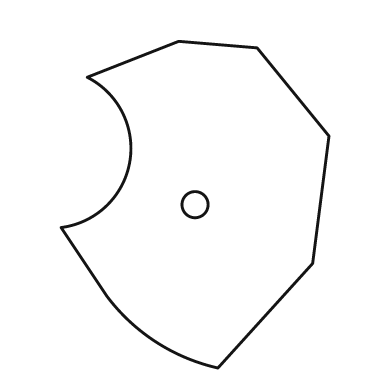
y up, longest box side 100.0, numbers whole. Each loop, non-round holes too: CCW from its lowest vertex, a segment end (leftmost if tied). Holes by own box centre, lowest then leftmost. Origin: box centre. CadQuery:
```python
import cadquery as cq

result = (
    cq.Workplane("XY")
    .moveTo(7.0, -50.0)
    .lineTo(36.0, -18.0)
    .lineTo(41.0, 21.0)
    .lineTo(19.0, 48.0)
    .lineTo(-5.0, 50.0)
    .lineTo(-33.0, 39.0)
    .threePointArc((-20.0, 13.0), (-41.0, -7.0))
    .lineTo(-27.0, -28.0)
    .threePointArc((-12.0, -42.0), (7.0, -50.0))
    .close()
    .moveTo(0.0, 0.0)
    .circle(4.0)
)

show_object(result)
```